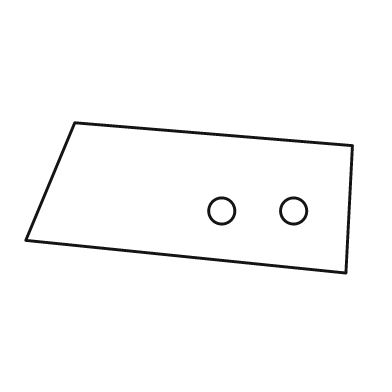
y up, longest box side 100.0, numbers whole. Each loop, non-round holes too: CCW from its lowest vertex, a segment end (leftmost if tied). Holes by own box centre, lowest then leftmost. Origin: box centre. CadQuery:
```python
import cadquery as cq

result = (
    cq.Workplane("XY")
    .moveTo(48.0, -23.0)
    .lineTo(50.0, 16.0)
    .lineTo(-35.0, 23.0)
    .lineTo(-50.0, -13.0)
    .close()
    .moveTo(10.0, -4.0)
    .circle(4.0)
    .moveTo(32.0, -4.0)
    .circle(4.0)
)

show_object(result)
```